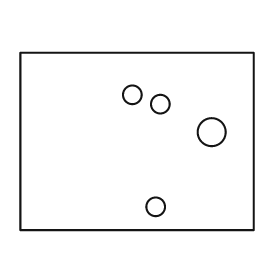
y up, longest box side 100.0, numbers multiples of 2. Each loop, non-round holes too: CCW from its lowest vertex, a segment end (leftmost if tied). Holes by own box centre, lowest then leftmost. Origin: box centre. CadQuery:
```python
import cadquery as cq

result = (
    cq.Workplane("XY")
    .moveTo(-50.0, -38.0)
    .lineTo(50.0, -38.0)
    .lineTo(50.0, 38.0)
    .lineTo(-50.0, 38.0)
    .close()
    .moveTo(8.0, -28.0)
    .circle(4.0)
    .moveTo(32.0, 4.0)
    .circle(6.0)
    .moveTo(10.0, 16.0)
    .circle(4.0)
    .moveTo(-2.0, 20.0)
    .circle(4.0)
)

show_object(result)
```